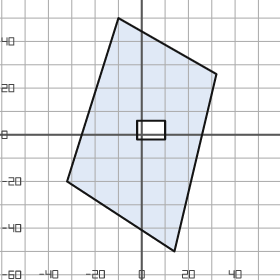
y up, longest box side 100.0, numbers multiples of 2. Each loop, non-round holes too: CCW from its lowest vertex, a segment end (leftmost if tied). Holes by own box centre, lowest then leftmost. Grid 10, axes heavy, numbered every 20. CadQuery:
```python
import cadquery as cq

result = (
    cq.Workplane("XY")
    .moveTo(14.0, -50.0)
    .lineTo(32.0, 26.0)
    .lineTo(-10.0, 50.0)
    .lineTo(-32.0, -20.0)
    .close()
    .moveTo(-2.0, -2.0)
    .lineTo(10.0, -2.0)
    .lineTo(10.0, 6.0)
    .lineTo(-2.0, 6.0)
    .close()
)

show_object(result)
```